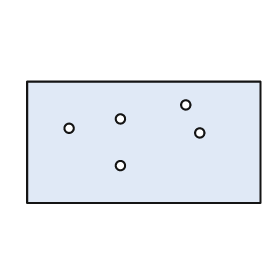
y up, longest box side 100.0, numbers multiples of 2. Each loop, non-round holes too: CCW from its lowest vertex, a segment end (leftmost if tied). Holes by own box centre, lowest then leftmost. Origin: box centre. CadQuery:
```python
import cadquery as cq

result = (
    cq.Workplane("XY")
    .moveTo(-50.0, -26.0)
    .lineTo(50.0, -26.0)
    .lineTo(50.0, 26.0)
    .lineTo(-50.0, 26.0)
    .close()
    .moveTo(-10.0, -10.0)
    .circle(2.0)
    .moveTo(24.0, 4.0)
    .circle(2.0)
    .moveTo(-32.0, 6.0)
    .circle(2.0)
    .moveTo(-10.0, 10.0)
    .circle(2.0)
    .moveTo(18.0, 16.0)
    .circle(2.0)
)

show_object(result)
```